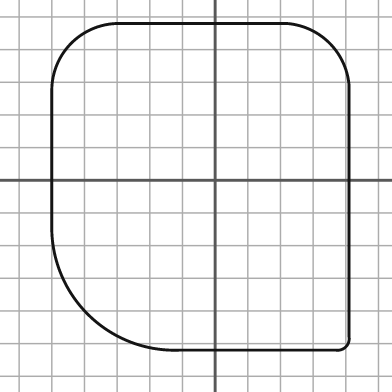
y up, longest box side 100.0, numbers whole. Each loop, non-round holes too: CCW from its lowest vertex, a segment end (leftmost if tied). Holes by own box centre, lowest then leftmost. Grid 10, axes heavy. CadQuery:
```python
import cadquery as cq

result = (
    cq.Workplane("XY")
    .moveTo(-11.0, -52.0)
    .lineTo(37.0, -52.0)
    .threePointArc((40.0, -51.0), (41.0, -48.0))
    .lineTo(41.0, 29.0)
    .threePointArc((35.0, 42.0), (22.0, 48.0))
    .lineTo(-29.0, 48.0)
    .threePointArc((-44.0, 42.0), (-50.0, 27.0))
    .lineTo(-50.0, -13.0)
    .threePointArc((-39.0, -41.0), (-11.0, -52.0))
    .close()
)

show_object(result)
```